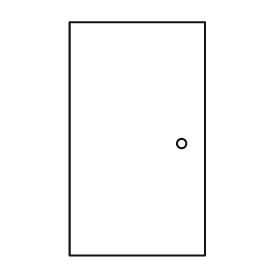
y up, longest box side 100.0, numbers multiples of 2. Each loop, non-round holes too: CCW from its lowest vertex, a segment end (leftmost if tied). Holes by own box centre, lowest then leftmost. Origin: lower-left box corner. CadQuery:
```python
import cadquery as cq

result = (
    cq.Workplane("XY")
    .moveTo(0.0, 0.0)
    .lineTo(58.0, 0.0)
    .lineTo(58.0, 100.0)
    .lineTo(0.0, 100.0)
    .close()
    .moveTo(48.0, 48.0)
    .circle(2.0)
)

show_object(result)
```